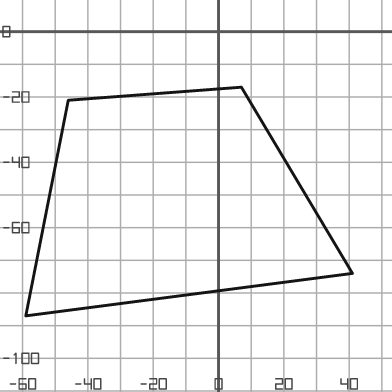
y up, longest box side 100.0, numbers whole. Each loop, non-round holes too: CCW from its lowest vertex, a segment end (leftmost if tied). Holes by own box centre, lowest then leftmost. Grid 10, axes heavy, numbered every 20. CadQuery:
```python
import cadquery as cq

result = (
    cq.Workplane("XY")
    .moveTo(-59.0, -87.0)
    .lineTo(41.0, -74.0)
    .lineTo(7.0, -17.0)
    .lineTo(-46.0, -21.0)
    .close()
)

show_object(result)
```